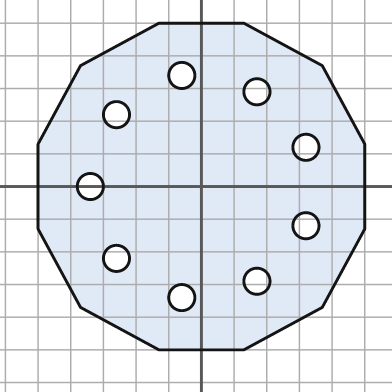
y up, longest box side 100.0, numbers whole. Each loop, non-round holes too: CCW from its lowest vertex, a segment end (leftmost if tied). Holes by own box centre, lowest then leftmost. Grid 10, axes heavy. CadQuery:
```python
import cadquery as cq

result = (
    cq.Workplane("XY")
    .moveTo(-13.0, -50.0)
    .lineTo(13.0, -50.0)
    .lineTo(37.0, -37.0)
    .lineTo(50.0, -13.0)
    .lineTo(50.0, 13.0)
    .lineTo(37.0, 37.0)
    .lineTo(13.0, 50.0)
    .lineTo(-13.0, 50.0)
    .lineTo(-37.0, 37.0)
    .lineTo(-50.0, 13.0)
    .lineTo(-50.0, -13.0)
    .lineTo(-37.0, -37.0)
    .close()
    .moveTo(-6.0, -34.0)
    .circle(4.0)
    .moveTo(17.0, -29.0)
    .circle(4.0)
    .moveTo(-26.0, -22.0)
    .circle(4.0)
    .moveTo(32.0, -12.0)
    .circle(4.0)
    .moveTo(-34.0, 0.0)
    .circle(4.0)
    .moveTo(32.0, 12.0)
    .circle(4.0)
    .moveTo(-26.0, 22.0)
    .circle(4.0)
    .moveTo(17.0, 29.0)
    .circle(4.0)
    .moveTo(-6.0, 34.0)
    .circle(4.0)
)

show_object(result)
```